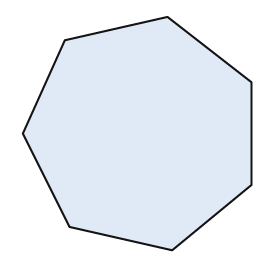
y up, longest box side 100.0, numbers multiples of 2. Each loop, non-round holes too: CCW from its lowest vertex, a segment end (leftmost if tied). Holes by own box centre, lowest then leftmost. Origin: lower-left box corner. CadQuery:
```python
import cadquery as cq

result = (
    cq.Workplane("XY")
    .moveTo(64.0, 0.0)
    .lineTo(98.0, 28.0)
    .lineTo(98.0, 72.0)
    .lineTo(62.0, 100.0)
    .lineTo(18.0, 90.0)
    .lineTo(0.0, 50.0)
    .lineTo(20.0, 10.0)
    .close()
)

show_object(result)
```